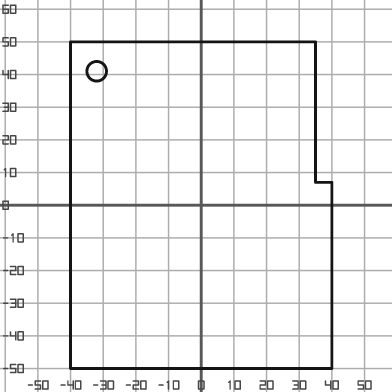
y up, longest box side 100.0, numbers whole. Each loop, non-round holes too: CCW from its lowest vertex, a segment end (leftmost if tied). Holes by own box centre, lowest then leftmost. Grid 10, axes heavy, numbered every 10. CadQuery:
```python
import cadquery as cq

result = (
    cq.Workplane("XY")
    .moveTo(-40.0, -50.0)
    .lineTo(40.0, -50.0)
    .lineTo(40.0, 7.0)
    .lineTo(35.0, 7.0)
    .lineTo(35.0, 50.0)
    .lineTo(-40.0, 50.0)
    .close()
    .moveTo(-32.0, 41.0)
    .circle(3.0)
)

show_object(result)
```